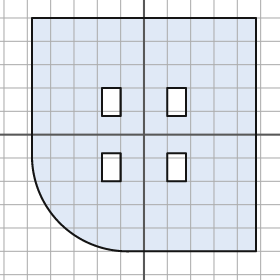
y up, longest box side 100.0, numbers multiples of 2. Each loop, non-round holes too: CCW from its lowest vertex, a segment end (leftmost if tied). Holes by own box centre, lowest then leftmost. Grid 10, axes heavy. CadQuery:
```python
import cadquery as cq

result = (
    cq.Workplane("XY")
    .moveTo(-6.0, -50.0)
    .lineTo(48.0, -50.0)
    .lineTo(48.0, 50.0)
    .lineTo(-48.0, 50.0)
    .lineTo(-48.0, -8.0)
    .threePointArc((-36.0, -38.0), (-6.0, -50.0))
    .close()
    .moveTo(-18.0, -20.0)
    .lineTo(-10.0, -20.0)
    .lineTo(-10.0, -8.0)
    .lineTo(-18.0, -8.0)
    .close()
    .moveTo(10.0, -20.0)
    .lineTo(18.0, -20.0)
    .lineTo(18.0, -8.0)
    .lineTo(10.0, -8.0)
    .close()
    .moveTo(-18.0, 8.0)
    .lineTo(-10.0, 8.0)
    .lineTo(-10.0, 20.0)
    .lineTo(-18.0, 20.0)
    .close()
    .moveTo(10.0, 8.0)
    .lineTo(18.0, 8.0)
    .lineTo(18.0, 20.0)
    .lineTo(10.0, 20.0)
    .close()
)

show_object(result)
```